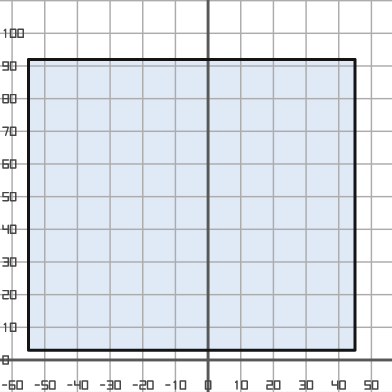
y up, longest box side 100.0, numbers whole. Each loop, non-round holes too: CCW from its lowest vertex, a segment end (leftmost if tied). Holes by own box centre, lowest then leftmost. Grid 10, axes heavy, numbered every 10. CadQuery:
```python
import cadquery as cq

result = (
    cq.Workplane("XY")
    .moveTo(-55.0, 3.0)
    .lineTo(45.0, 3.0)
    .lineTo(45.0, 92.0)
    .lineTo(-55.0, 92.0)
    .close()
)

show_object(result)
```